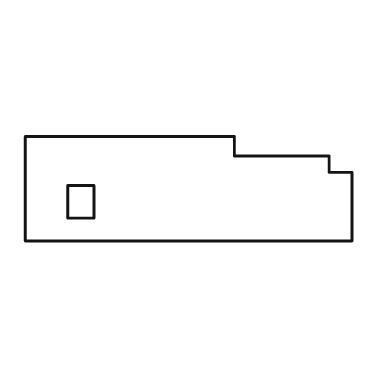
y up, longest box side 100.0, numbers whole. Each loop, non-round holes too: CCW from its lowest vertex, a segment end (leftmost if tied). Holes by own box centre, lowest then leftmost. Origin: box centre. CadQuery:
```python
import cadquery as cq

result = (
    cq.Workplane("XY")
    .moveTo(-50.0, -16.0)
    .lineTo(50.0, -16.0)
    .lineTo(50.0, 5.0)
    .lineTo(43.0, 5.0)
    .lineTo(43.0, 10.0)
    .lineTo(14.0, 10.0)
    .lineTo(14.0, 16.0)
    .lineTo(-50.0, 16.0)
    .close()
    .moveTo(-37.0, -9.0)
    .lineTo(-29.0, -9.0)
    .lineTo(-29.0, 1.0)
    .lineTo(-37.0, 1.0)
    .close()
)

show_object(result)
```